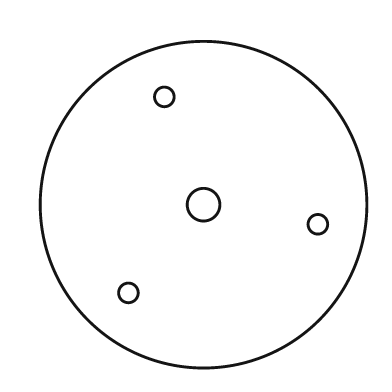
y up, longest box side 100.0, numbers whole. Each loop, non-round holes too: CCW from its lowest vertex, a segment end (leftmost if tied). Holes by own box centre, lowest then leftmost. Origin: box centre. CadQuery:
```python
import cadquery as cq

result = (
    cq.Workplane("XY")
    .moveTo(0.0, 0.0)
    .circle(50.0)
    .moveTo(-23.0, -27.0)
    .circle(3.0)
    .moveTo(35.0, -6.0)
    .circle(3.0)
    .moveTo(0.0, 0.0)
    .circle(5.0)
    .moveTo(-12.0, 33.0)
    .circle(3.0)
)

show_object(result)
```